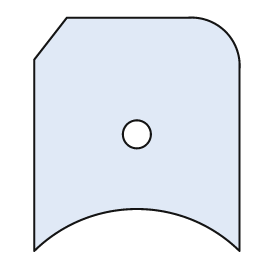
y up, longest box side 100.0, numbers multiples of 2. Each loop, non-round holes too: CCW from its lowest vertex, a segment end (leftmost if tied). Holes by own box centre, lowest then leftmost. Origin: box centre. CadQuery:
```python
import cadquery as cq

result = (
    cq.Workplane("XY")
    .moveTo(-44.0, -50.0)
    .threePointArc((0.0, -32.0), (44.0, -50.0))
    .lineTo(44.0, 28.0)
    .threePointArc((38.0, 44.0), (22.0, 50.0))
    .lineTo(-30.0, 50.0)
    .lineTo(-44.0, 32.0)
    .close()
    .moveTo(0.0, 0.0)
    .circle(6.0)
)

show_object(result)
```